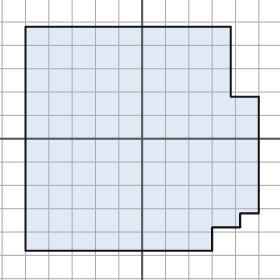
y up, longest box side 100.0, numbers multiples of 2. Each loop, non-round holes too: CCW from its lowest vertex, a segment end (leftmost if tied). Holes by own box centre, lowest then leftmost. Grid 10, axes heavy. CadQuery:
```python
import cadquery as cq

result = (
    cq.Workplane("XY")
    .moveTo(-50.0, -48.0)
    .lineTo(30.0, -48.0)
    .lineTo(30.0, -38.0)
    .lineTo(42.0, -38.0)
    .lineTo(42.0, -32.0)
    .lineTo(50.0, -32.0)
    .lineTo(50.0, 18.0)
    .lineTo(38.0, 18.0)
    .lineTo(38.0, 48.0)
    .lineTo(-50.0, 48.0)
    .close()
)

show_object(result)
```